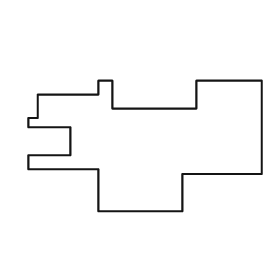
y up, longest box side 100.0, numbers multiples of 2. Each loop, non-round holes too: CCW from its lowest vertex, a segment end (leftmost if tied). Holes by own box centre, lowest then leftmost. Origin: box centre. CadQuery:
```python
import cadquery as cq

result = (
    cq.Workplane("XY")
    .moveTo(-20.0, -28.0)
    .lineTo(16.0, -28.0)
    .lineTo(16.0, -12.0)
    .lineTo(50.0, -12.0)
    .lineTo(50.0, 28.0)
    .lineTo(22.0, 28.0)
    .lineTo(22.0, 16.0)
    .lineTo(-14.0, 16.0)
    .lineTo(-14.0, 28.0)
    .lineTo(-20.0, 28.0)
    .lineTo(-20.0, 22.0)
    .lineTo(-46.0, 22.0)
    .lineTo(-46.0, 12.0)
    .lineTo(-50.0, 12.0)
    .lineTo(-50.0, 8.0)
    .lineTo(-32.0, 8.0)
    .lineTo(-32.0, -4.0)
    .lineTo(-50.0, -4.0)
    .lineTo(-50.0, -10.0)
    .lineTo(-20.0, -10.0)
    .close()
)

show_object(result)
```